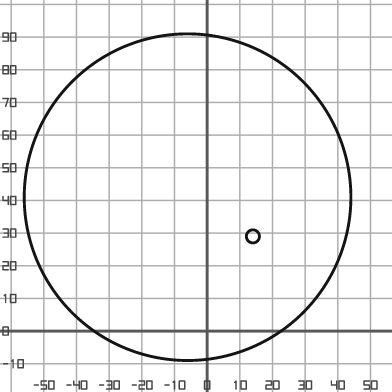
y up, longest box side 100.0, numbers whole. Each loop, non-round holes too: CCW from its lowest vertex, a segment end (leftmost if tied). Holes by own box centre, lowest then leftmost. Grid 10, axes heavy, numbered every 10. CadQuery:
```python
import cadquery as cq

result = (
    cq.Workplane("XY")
    .moveTo(-6.0, 41.0)
    .circle(50.0)
    .moveTo(14.0, 29.0)
    .circle(2.0)
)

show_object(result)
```